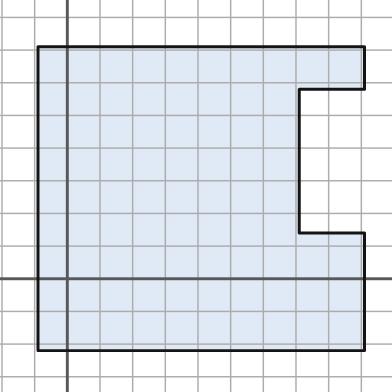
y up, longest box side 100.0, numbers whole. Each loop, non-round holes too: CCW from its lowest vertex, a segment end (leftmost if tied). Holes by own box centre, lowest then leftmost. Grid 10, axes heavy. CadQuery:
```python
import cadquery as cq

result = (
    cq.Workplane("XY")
    .moveTo(-9.0, -22.0)
    .lineTo(91.0, -22.0)
    .lineTo(91.0, 14.0)
    .lineTo(71.0, 14.0)
    .lineTo(71.0, 58.0)
    .lineTo(91.0, 58.0)
    .lineTo(91.0, 71.0)
    .lineTo(-9.0, 71.0)
    .close()
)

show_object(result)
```